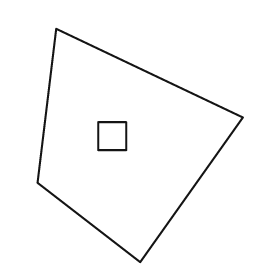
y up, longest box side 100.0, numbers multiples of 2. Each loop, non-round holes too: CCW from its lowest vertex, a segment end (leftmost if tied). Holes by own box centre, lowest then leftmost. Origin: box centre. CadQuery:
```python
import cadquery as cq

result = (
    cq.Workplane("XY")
    .moveTo(0.0, -50.0)
    .lineTo(44.0, 12.0)
    .lineTo(-36.0, 50.0)
    .lineTo(-44.0, -16.0)
    .close()
    .moveTo(-18.0, -2.0)
    .lineTo(-6.0, -2.0)
    .lineTo(-6.0, 10.0)
    .lineTo(-18.0, 10.0)
    .close()
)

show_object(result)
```